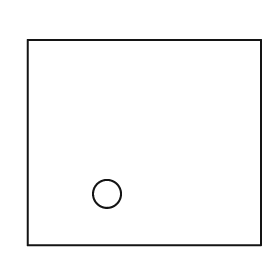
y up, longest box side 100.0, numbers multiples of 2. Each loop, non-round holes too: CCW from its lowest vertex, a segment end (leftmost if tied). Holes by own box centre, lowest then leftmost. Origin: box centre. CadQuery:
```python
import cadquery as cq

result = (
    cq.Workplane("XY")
    .moveTo(-50.0, -44.0)
    .lineTo(50.0, -44.0)
    .lineTo(50.0, 44.0)
    .lineTo(-50.0, 44.0)
    .close()
    .moveTo(-16.0, -22.0)
    .circle(6.0)
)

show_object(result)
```